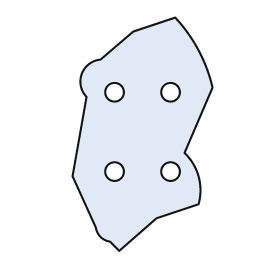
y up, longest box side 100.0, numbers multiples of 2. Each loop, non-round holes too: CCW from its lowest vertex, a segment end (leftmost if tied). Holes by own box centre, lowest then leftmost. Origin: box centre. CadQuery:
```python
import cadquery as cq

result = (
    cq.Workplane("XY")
    .moveTo(-10.0, -50.0)
    .lineTo(6.0, -36.0)
    .lineTo(24.0, -30.0)
    .threePointArc((24.0, -18.0), (18.0, -8.0))
    .lineTo(30.0, 20.0)
    .threePointArc((24.0, 36.0), (14.0, 50.0))
    .lineTo(-4.0, 44.0)
    .lineTo(-18.0, 32.0)
    .threePointArc((-26.0, 26.0), (-24.0, 16.0))
    .lineTo(-30.0, -18.0)
    .lineTo(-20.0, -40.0)
    .threePointArc((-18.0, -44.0), (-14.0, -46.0))
    .close()
    .moveTo(-12.0, -16.0)
    .circle(4.0)
    .moveTo(12.0, -16.0)
    .circle(4.0)
    .moveTo(-12.0, 18.0)
    .circle(4.0)
    .moveTo(12.0, 18.0)
    .circle(4.0)
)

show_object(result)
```